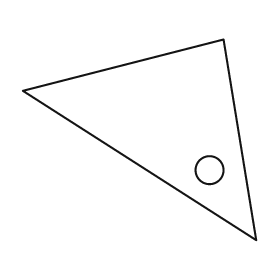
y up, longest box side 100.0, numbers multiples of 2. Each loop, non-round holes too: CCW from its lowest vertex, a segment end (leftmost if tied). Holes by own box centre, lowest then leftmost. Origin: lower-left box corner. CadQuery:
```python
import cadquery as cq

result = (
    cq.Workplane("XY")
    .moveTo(100.0, 0.0)
    .lineTo(86.0, 86.0)
    .lineTo(0.0, 64.0)
    .close()
    .moveTo(80.0, 30.0)
    .circle(6.0)
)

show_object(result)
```